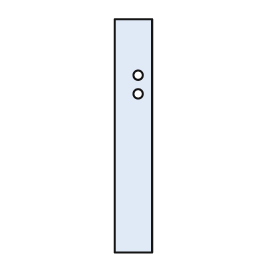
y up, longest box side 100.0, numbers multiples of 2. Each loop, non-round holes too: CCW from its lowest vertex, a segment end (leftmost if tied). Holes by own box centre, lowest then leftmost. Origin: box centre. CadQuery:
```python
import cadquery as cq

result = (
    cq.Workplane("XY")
    .moveTo(-8.0, -50.0)
    .lineTo(8.0, -50.0)
    .lineTo(8.0, 50.0)
    .lineTo(-8.0, 50.0)
    .close()
    .moveTo(2.0, 18.0)
    .circle(2.0)
    .moveTo(2.0, 26.0)
    .circle(2.0)
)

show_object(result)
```